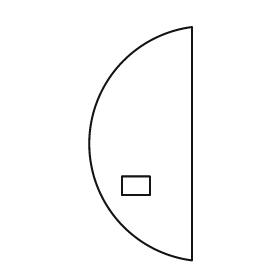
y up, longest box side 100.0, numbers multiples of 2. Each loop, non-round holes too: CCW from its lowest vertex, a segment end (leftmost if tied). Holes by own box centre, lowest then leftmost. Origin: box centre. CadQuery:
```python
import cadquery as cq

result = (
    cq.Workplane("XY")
    .moveTo(22.0, -50.0)
    .lineTo(22.0, 50.0)
    .threePointArc((-22.0, 0.0), (22.0, -50.0))
    .close()
    .moveTo(-8.0, -22.0)
    .lineTo(4.0, -22.0)
    .lineTo(4.0, -14.0)
    .lineTo(-8.0, -14.0)
    .close()
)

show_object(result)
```